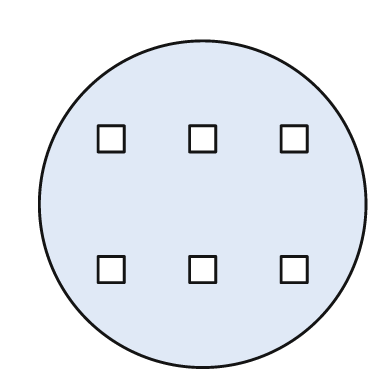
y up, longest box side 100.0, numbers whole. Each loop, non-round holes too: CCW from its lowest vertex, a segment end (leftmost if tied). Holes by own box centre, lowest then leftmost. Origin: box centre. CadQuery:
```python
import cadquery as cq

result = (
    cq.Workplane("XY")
    .moveTo(0.0, 0.0)
    .circle(50.0)
    .moveTo(-32.0, -24.0)
    .lineTo(-24.0, -24.0)
    .lineTo(-24.0, -16.0)
    .lineTo(-32.0, -16.0)
    .close()
    .moveTo(-4.0, -24.0)
    .lineTo(4.0, -24.0)
    .lineTo(4.0, -16.0)
    .lineTo(-4.0, -16.0)
    .close()
    .moveTo(24.0, -24.0)
    .lineTo(32.0, -24.0)
    .lineTo(32.0, -16.0)
    .lineTo(24.0, -16.0)
    .close()
    .moveTo(-32.0, 16.0)
    .lineTo(-24.0, 16.0)
    .lineTo(-24.0, 24.0)
    .lineTo(-32.0, 24.0)
    .close()
    .moveTo(-4.0, 16.0)
    .lineTo(4.0, 16.0)
    .lineTo(4.0, 24.0)
    .lineTo(-4.0, 24.0)
    .close()
    .moveTo(24.0, 16.0)
    .lineTo(32.0, 16.0)
    .lineTo(32.0, 24.0)
    .lineTo(24.0, 24.0)
    .close()
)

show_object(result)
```